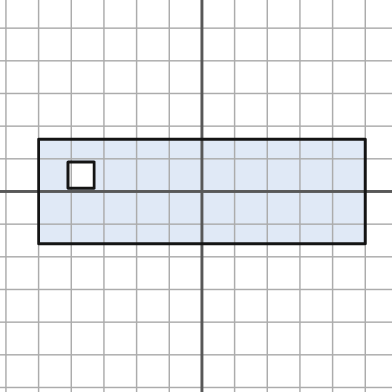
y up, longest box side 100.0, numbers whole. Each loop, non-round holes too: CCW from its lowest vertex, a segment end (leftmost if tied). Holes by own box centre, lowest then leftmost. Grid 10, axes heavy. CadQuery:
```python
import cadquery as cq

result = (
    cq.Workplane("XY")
    .moveTo(-50.0, -16.0)
    .lineTo(50.0, -16.0)
    .lineTo(50.0, 16.0)
    .lineTo(-50.0, 16.0)
    .close()
    .moveTo(-41.0, 1.0)
    .lineTo(-33.0, 1.0)
    .lineTo(-33.0, 9.0)
    .lineTo(-41.0, 9.0)
    .close()
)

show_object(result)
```